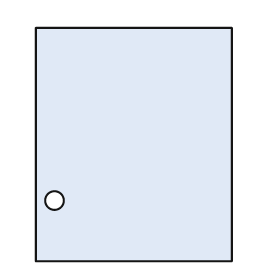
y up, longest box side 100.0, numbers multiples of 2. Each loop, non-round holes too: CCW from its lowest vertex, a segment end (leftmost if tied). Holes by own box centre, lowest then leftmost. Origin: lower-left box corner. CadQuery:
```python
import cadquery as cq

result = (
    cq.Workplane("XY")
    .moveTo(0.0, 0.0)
    .lineTo(84.0, 0.0)
    .lineTo(84.0, 100.0)
    .lineTo(0.0, 100.0)
    .close()
    .moveTo(8.0, 26.0)
    .circle(4.0)
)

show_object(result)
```